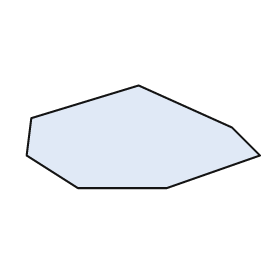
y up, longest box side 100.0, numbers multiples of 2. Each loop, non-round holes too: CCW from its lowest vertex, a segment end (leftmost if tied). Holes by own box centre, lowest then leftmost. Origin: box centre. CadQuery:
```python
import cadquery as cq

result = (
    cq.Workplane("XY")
    .moveTo(-28.0, -22.0)
    .lineTo(10.0, -22.0)
    .lineTo(50.0, -8.0)
    .lineTo(38.0, 4.0)
    .lineTo(-2.0, 22.0)
    .lineTo(-48.0, 8.0)
    .lineTo(-50.0, -8.0)
    .close()
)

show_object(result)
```